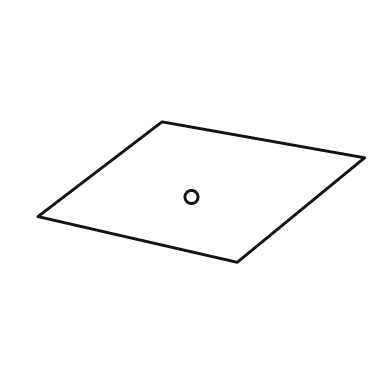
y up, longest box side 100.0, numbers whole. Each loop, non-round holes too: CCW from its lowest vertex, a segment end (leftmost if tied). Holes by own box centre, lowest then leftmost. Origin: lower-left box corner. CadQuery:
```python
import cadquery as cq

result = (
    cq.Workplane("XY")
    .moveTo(61.0, 0.0)
    .lineTo(100.0, 32.0)
    .lineTo(38.0, 43.0)
    .lineTo(0.0, 14.0)
    .close()
    .moveTo(47.0, 20.0)
    .circle(2.0)
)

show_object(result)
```